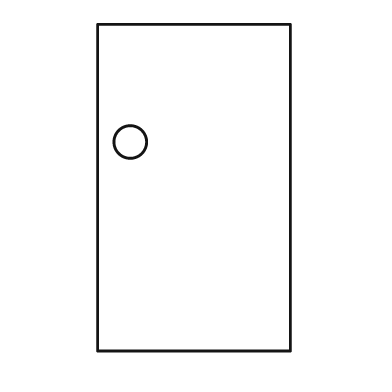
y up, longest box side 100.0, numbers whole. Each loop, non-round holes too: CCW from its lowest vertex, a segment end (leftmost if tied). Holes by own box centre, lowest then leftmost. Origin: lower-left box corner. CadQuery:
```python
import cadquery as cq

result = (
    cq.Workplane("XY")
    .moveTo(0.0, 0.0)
    .lineTo(59.0, 0.0)
    .lineTo(59.0, 100.0)
    .lineTo(0.0, 100.0)
    .close()
    .moveTo(10.0, 64.0)
    .circle(5.0)
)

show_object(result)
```